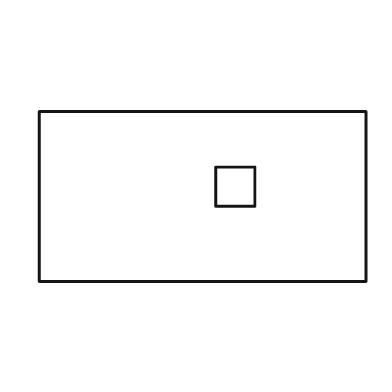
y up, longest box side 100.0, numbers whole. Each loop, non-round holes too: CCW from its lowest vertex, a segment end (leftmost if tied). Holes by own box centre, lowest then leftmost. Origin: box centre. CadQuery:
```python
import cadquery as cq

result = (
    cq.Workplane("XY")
    .moveTo(-50.0, -26.0)
    .lineTo(50.0, -26.0)
    .lineTo(50.0, 26.0)
    .lineTo(-50.0, 26.0)
    .close()
    .moveTo(4.0, -3.0)
    .lineTo(16.0, -3.0)
    .lineTo(16.0, 9.0)
    .lineTo(4.0, 9.0)
    .close()
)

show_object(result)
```